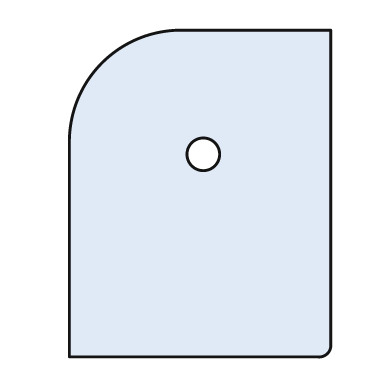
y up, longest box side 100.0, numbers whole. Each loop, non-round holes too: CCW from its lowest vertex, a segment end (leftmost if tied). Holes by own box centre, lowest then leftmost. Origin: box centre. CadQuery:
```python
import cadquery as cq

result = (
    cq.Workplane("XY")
    .moveTo(-40.0, -50.0)
    .lineTo(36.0, -50.0)
    .threePointArc((39.0, -49.0), (40.0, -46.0))
    .lineTo(40.0, 50.0)
    .lineTo(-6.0, 50.0)
    .threePointArc((-30.0, 40.0), (-40.0, 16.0))
    .close()
    .moveTo(1.0, 12.0)
    .circle(5.0)
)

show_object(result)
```